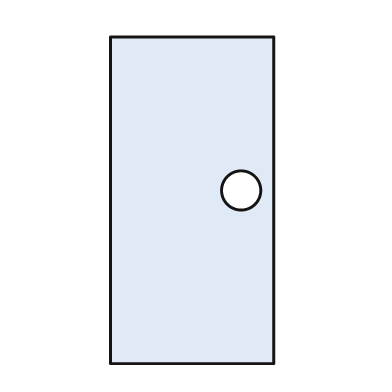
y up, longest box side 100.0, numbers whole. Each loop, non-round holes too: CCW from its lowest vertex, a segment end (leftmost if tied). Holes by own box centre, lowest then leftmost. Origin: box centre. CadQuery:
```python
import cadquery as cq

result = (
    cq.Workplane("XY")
    .moveTo(-25.0, -50.0)
    .lineTo(25.0, -50.0)
    .lineTo(25.0, 50.0)
    .lineTo(-25.0, 50.0)
    .close()
    .moveTo(15.0, 3.0)
    .circle(6.0)
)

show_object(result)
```